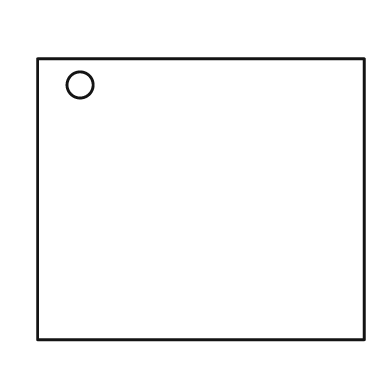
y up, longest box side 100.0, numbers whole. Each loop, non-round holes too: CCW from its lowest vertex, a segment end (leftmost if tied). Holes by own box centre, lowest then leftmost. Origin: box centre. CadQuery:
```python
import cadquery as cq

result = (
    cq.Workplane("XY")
    .moveTo(-50.0, -43.0)
    .lineTo(50.0, -43.0)
    .lineTo(50.0, 43.0)
    .lineTo(-50.0, 43.0)
    .close()
    .moveTo(-37.0, 35.0)
    .circle(4.0)
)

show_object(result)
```